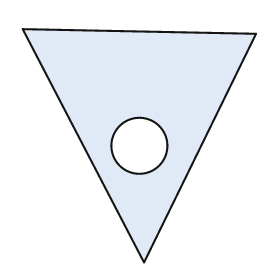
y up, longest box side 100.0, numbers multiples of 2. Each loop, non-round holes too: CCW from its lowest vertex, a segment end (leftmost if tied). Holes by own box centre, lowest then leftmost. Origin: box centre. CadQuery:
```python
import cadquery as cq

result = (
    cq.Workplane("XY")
    .moveTo(2.0, -50.0)
    .lineTo(50.0, 48.0)
    .lineTo(-50.0, 50.0)
    .close()
    .moveTo(0.0, 0.0)
    .circle(12.0)
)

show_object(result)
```